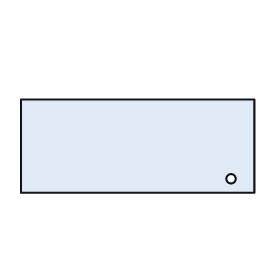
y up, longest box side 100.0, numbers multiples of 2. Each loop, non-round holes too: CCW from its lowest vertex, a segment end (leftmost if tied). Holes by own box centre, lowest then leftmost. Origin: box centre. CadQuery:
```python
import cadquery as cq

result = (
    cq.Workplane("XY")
    .moveTo(-50.0, -20.0)
    .lineTo(50.0, -20.0)
    .lineTo(50.0, 20.0)
    .lineTo(-50.0, 20.0)
    .close()
    .moveTo(40.0, -14.0)
    .circle(2.0)
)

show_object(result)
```